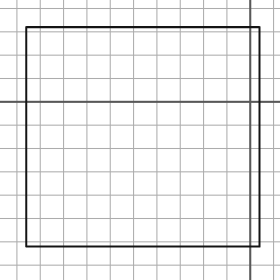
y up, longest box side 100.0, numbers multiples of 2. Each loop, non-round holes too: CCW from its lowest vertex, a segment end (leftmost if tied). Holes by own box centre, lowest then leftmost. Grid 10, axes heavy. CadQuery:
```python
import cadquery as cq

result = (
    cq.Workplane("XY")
    .moveTo(-96.0, -62.0)
    .lineTo(4.0, -62.0)
    .lineTo(4.0, 32.0)
    .lineTo(-96.0, 32.0)
    .close()
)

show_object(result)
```